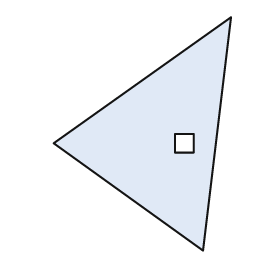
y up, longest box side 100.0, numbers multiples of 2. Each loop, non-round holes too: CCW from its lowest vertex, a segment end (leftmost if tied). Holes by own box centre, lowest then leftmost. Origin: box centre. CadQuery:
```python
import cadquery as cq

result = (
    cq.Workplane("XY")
    .moveTo(26.0, -50.0)
    .lineTo(38.0, 50.0)
    .lineTo(-38.0, -4.0)
    .close()
    .moveTo(14.0, -8.0)
    .lineTo(22.0, -8.0)
    .lineTo(22.0, 0.0)
    .lineTo(14.0, 0.0)
    .close()
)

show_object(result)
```